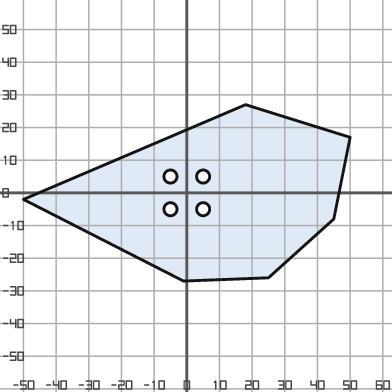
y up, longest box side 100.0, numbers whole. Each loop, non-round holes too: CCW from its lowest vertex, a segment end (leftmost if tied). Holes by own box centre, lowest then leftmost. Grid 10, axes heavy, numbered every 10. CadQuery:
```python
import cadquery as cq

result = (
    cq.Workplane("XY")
    .moveTo(-1.0, -27.0)
    .lineTo(25.0, -26.0)
    .lineTo(45.0, -8.0)
    .lineTo(50.0, 17.0)
    .lineTo(18.0, 27.0)
    .lineTo(-50.0, -2.0)
    .close()
    .moveTo(-5.0, -5.0)
    .circle(2.0)
    .moveTo(5.0, -5.0)
    .circle(2.0)
    .moveTo(-5.0, 5.0)
    .circle(2.0)
    .moveTo(5.0, 5.0)
    .circle(2.0)
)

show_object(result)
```